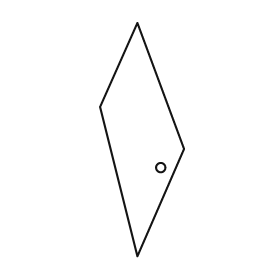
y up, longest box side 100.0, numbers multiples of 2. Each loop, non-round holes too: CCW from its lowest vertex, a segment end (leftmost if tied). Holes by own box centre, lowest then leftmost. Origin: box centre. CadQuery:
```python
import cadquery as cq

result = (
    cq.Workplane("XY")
    .moveTo(-2.0, -50.0)
    .lineTo(18.0, -4.0)
    .lineTo(-2.0, 50.0)
    .lineTo(-18.0, 14.0)
    .close()
    .moveTo(8.0, -12.0)
    .circle(2.0)
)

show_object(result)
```